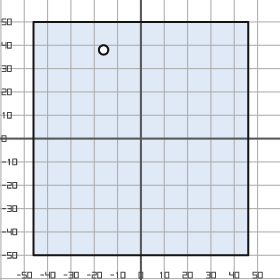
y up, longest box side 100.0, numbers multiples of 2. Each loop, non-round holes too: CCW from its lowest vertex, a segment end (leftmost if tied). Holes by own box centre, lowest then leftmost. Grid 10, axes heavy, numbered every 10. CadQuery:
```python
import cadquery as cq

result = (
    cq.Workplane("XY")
    .moveTo(-46.0, -50.0)
    .lineTo(46.0, -50.0)
    .lineTo(46.0, 50.0)
    .lineTo(-46.0, 50.0)
    .close()
    .moveTo(-16.0, 38.0)
    .circle(2.0)
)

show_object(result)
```